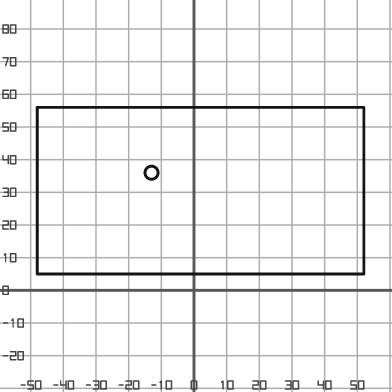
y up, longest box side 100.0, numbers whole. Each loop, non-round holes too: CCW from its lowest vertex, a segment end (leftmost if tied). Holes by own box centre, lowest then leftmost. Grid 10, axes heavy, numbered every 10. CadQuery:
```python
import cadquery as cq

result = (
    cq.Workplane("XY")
    .moveTo(-48.0, 5.0)
    .lineTo(52.0, 5.0)
    .lineTo(52.0, 56.0)
    .lineTo(-48.0, 56.0)
    .close()
    .moveTo(-13.0, 36.0)
    .circle(2.0)
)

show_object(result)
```